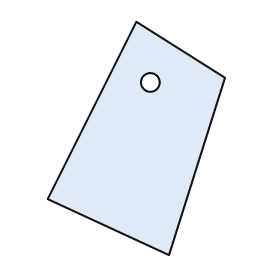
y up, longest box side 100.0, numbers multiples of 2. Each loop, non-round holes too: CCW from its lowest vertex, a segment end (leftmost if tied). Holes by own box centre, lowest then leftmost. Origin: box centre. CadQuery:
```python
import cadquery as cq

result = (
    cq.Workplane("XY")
    .moveTo(14.0, -50.0)
    .lineTo(38.0, 26.0)
    .lineTo(0.0, 50.0)
    .lineTo(-38.0, -26.0)
    .close()
    .moveTo(6.0, 24.0)
    .circle(4.0)
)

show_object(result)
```